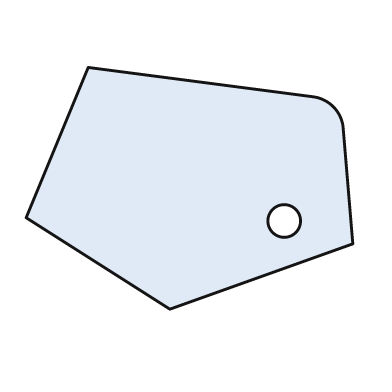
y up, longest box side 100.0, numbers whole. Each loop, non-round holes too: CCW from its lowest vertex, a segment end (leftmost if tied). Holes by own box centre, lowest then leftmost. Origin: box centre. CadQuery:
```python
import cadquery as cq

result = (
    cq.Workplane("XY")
    .moveTo(-6.0, -37.0)
    .lineTo(50.0, -17.0)
    .lineTo(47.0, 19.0)
    .threePointArc((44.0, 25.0), (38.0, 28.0))
    .lineTo(-31.0, 37.0)
    .lineTo(-50.0, -9.0)
    .close()
    .moveTo(29.0, -10.0)
    .circle(5.0)
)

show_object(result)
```